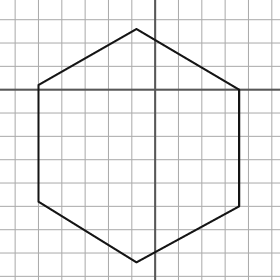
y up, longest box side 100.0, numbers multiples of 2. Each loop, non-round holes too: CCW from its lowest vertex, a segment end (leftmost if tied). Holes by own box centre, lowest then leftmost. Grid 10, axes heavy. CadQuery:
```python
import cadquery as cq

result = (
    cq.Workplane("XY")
    .moveTo(-8.0, -74.0)
    .lineTo(36.0, -50.0)
    .lineTo(36.0, 0.0)
    .lineTo(-8.0, 26.0)
    .lineTo(-50.0, 2.0)
    .lineTo(-50.0, -48.0)
    .close()
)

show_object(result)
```